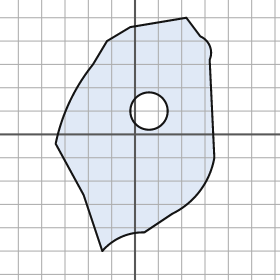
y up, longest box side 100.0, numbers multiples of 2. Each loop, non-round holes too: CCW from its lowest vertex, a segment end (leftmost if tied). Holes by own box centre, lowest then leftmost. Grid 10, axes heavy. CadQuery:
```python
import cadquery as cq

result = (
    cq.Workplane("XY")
    .moveTo(-14.0, -50.0)
    .threePointArc((-6.0, -44.0), (4.0, -42.0))
    .lineTo(16.0, -34.0)
    .threePointArc((28.0, -24.0), (34.0, -10.0))
    .lineTo(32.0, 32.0)
    .threePointArc((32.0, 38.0), (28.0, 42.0))
    .lineTo(22.0, 50.0)
    .lineTo(-2.0, 46.0)
    .lineTo(-12.0, 40.0)
    .lineTo(-18.0, 30.0)
    .threePointArc((-28.0, 14.0), (-34.0, -4.0))
    .lineTo(-22.0, -26.0)
    .close()
    .moveTo(6.0, 10.0)
    .circle(8.0)
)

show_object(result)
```